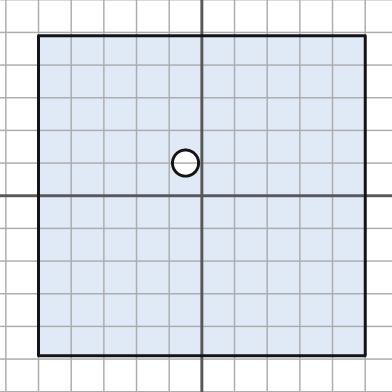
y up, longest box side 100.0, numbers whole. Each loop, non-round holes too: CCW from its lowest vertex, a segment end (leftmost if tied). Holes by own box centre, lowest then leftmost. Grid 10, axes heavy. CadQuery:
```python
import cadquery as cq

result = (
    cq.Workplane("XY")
    .moveTo(-50.0, -49.0)
    .lineTo(50.0, -49.0)
    .lineTo(50.0, 49.0)
    .lineTo(-50.0, 49.0)
    .close()
    .moveTo(-5.0, 10.0)
    .circle(4.0)
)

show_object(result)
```